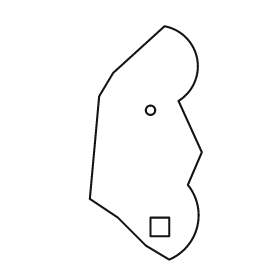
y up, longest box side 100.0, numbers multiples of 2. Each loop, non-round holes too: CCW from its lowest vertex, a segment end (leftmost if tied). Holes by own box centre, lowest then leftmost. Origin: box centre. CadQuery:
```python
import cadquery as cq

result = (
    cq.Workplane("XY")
    .moveTo(10.0, -50.0)
    .threePointArc((22.0, -36.0), (18.0, -18.0))
    .lineTo(24.0, -4.0)
    .lineTo(14.0, 18.0)
    .threePointArc((22.0, 36.0), (8.0, 50.0))
    .lineTo(-14.0, 30.0)
    .lineTo(-20.0, 20.0)
    .lineTo(-24.0, -24.0)
    .lineTo(-12.0, -32.0)
    .lineTo(0.0, -44.0)
    .close()
    .moveTo(2.0, -40.0)
    .lineTo(10.0, -40.0)
    .lineTo(10.0, -32.0)
    .lineTo(2.0, -32.0)
    .close()
    .moveTo(2.0, 14.0)
    .circle(2.0)
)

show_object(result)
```